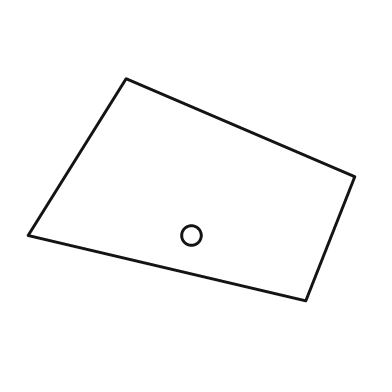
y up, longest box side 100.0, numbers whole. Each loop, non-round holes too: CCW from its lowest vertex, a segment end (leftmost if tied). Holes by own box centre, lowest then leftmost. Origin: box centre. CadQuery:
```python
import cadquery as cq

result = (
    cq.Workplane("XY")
    .moveTo(35.0, -34.0)
    .lineTo(50.0, 4.0)
    .lineTo(-20.0, 34.0)
    .lineTo(-50.0, -14.0)
    .close()
    .moveTo(0.0, -14.0)
    .circle(3.0)
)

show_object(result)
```